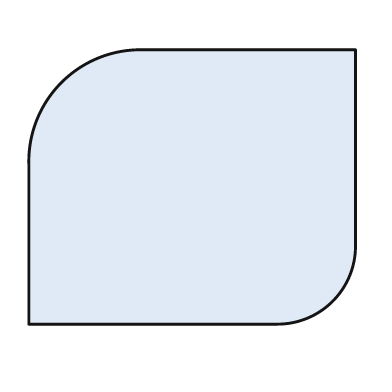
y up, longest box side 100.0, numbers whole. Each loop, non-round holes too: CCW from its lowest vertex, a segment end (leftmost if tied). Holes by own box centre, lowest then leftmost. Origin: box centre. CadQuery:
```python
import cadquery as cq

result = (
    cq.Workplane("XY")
    .moveTo(-50.0, -42.0)
    .lineTo(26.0, -42.0)
    .threePointArc((43.0, -35.0), (50.0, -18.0))
    .lineTo(50.0, 42.0)
    .lineTo(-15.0, 42.0)
    .threePointArc((-40.0, 32.0), (-50.0, 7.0))
    .close()
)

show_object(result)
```